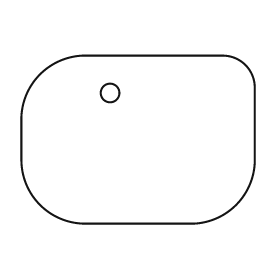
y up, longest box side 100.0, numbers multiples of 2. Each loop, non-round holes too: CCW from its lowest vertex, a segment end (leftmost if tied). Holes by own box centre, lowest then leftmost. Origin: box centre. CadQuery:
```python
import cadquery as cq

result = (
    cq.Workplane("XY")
    .moveTo(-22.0, -36.0)
    .lineTo(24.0, -36.0)
    .threePointArc((42.0, -28.0), (50.0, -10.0))
    .lineTo(50.0, 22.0)
    .threePointArc((46.0, 32.0), (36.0, 36.0))
    .lineTo(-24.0, 36.0)
    .threePointArc((-42.0, 28.0), (-50.0, 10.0))
    .lineTo(-50.0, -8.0)
    .threePointArc((-42.0, -28.0), (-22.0, -36.0))
    .close()
    .moveTo(-12.0, 20.0)
    .circle(4.0)
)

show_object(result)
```